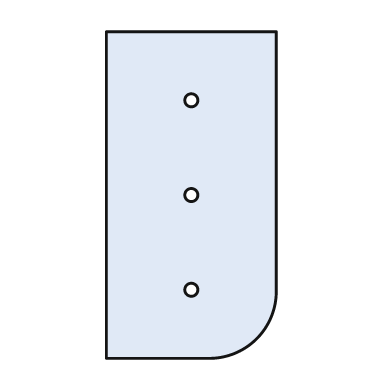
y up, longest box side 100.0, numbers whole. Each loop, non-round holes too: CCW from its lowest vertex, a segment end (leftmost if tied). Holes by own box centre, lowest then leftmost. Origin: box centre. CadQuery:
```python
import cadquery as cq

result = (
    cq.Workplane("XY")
    .moveTo(-26.0, -50.0)
    .lineTo(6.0, -50.0)
    .threePointArc((20.0, -44.0), (26.0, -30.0))
    .lineTo(26.0, 50.0)
    .lineTo(-26.0, 50.0)
    .close()
    .moveTo(0.0, -29.0)
    .circle(2.0)
    .moveTo(0.0, 0.0)
    .circle(2.0)
    .moveTo(0.0, 29.0)
    .circle(2.0)
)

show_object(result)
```